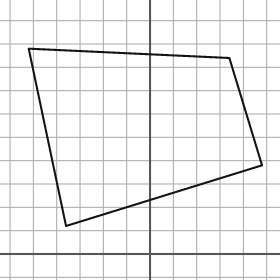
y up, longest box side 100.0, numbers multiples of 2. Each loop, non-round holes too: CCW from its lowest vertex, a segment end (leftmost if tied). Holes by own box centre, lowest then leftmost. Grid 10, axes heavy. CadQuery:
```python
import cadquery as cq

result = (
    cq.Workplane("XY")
    .moveTo(-36.0, 12.0)
    .lineTo(48.0, 38.0)
    .lineTo(34.0, 84.0)
    .lineTo(-52.0, 88.0)
    .close()
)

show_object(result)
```